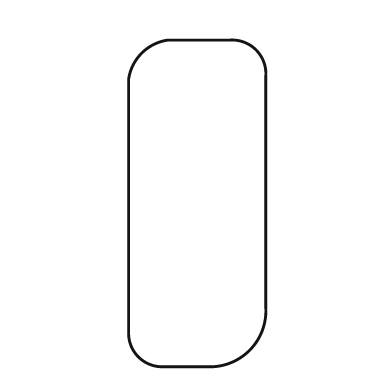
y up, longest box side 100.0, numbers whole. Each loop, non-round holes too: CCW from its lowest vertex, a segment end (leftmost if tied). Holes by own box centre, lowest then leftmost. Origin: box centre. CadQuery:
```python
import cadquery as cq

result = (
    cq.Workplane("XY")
    .moveTo(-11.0, -50.0)
    .lineTo(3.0, -50.0)
    .threePointArc((16.0, -45.0), (21.0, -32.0))
    .lineTo(21.0, 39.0)
    .threePointArc((18.0, 47.0), (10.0, 50.0))
    .lineTo(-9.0, 50.0)
    .threePointArc((-17.0, 46.0), (-21.0, 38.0))
    .lineTo(-21.0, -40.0)
    .threePointArc((-18.0, -47.0), (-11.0, -50.0))
    .close()
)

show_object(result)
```